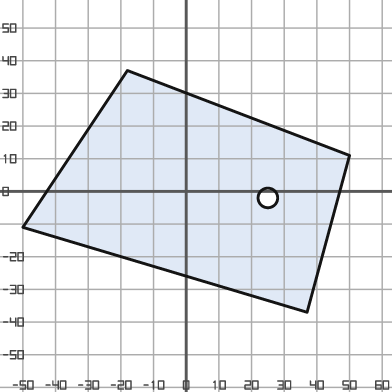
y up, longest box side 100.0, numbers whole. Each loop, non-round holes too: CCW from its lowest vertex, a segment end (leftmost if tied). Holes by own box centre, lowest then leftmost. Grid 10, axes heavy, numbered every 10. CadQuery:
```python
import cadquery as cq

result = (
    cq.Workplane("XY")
    .moveTo(37.0, -37.0)
    .lineTo(50.0, 11.0)
    .lineTo(-18.0, 37.0)
    .lineTo(-50.0, -11.0)
    .close()
    .moveTo(25.0, -2.0)
    .circle(3.0)
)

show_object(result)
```